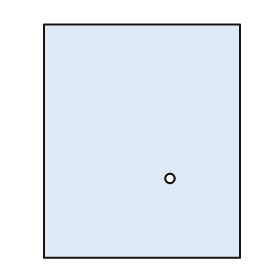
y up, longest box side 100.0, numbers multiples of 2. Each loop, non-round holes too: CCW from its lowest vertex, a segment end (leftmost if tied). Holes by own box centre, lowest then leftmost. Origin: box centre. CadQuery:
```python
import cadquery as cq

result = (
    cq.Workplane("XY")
    .moveTo(-42.0, -50.0)
    .lineTo(42.0, -50.0)
    .lineTo(42.0, 50.0)
    .lineTo(-42.0, 50.0)
    .close()
    .moveTo(12.0, -16.0)
    .circle(2.0)
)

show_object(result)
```